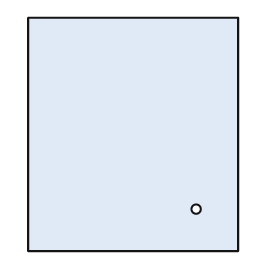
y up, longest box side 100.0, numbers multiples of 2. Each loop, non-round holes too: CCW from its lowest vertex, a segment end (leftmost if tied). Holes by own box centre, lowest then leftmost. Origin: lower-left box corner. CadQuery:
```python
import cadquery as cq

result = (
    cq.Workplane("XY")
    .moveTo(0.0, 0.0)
    .lineTo(90.0, 0.0)
    .lineTo(90.0, 100.0)
    .lineTo(0.0, 100.0)
    .close()
    .moveTo(72.0, 18.0)
    .circle(2.0)
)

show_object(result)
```